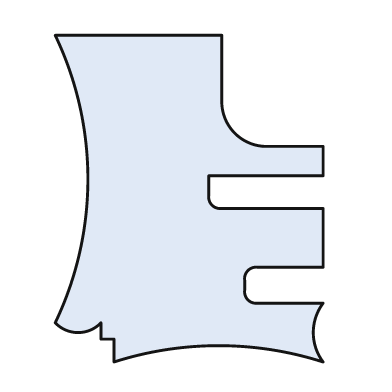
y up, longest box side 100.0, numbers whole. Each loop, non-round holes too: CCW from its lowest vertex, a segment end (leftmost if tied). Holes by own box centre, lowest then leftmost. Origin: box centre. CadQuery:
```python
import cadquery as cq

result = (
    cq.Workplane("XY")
    .moveTo(-23.0, -50.0)
    .threePointArc((9.0, -45.0), (41.0, -50.0))
    .threePointArc((38.0, -41.0), (41.0, -32.0))
    .lineTo(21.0, -32.0)
    .threePointArc((18.0, -31.0), (17.0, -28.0))
    .lineTo(17.0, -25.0)
    .threePointArc((18.0, -22.0), (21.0, -21.0))
    .lineTo(41.0, -21.0)
    .lineTo(41.0, -3.0)
    .lineTo(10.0, -3.0)
    .threePointArc((7.0, -2.0), (6.0, 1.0))
    .lineTo(6.0, 7.0)
    .lineTo(41.0, 7.0)
    .lineTo(41.0, 16.0)
    .lineTo(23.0, 16.0)
    .threePointArc((14.0, 20.0), (10.0, 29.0))
    .lineTo(10.0, 50.0)
    .lineTo(-41.0, 50.0)
    .threePointArc((-31.0, 6.0), (-41.0, -38.0))
    .threePointArc((-34.0, -41.0), (-27.0, -38.0))
    .lineTo(-27.0, -43.0)
    .lineTo(-23.0, -43.0)
    .close()
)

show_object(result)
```